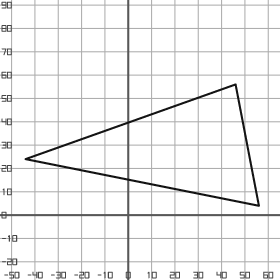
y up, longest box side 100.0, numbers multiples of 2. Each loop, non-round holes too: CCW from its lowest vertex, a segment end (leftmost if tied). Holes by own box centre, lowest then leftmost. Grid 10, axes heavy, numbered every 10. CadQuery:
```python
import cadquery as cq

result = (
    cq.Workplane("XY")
    .moveTo(56.0, 4.0)
    .lineTo(46.0, 56.0)
    .lineTo(-44.0, 24.0)
    .close()
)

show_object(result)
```